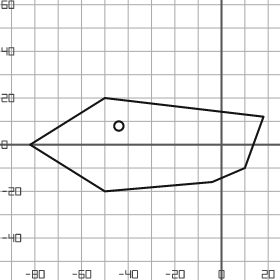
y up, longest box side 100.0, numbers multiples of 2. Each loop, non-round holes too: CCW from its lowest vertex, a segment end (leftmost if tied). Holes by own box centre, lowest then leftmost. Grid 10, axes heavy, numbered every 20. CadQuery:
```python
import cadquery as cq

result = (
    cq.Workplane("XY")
    .moveTo(-50.0, -20.0)
    .lineTo(-4.0, -16.0)
    .lineTo(10.0, -10.0)
    .lineTo(18.0, 12.0)
    .lineTo(-50.0, 20.0)
    .lineTo(-82.0, 0.0)
    .close()
    .moveTo(-44.0, 8.0)
    .circle(2.0)
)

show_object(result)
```